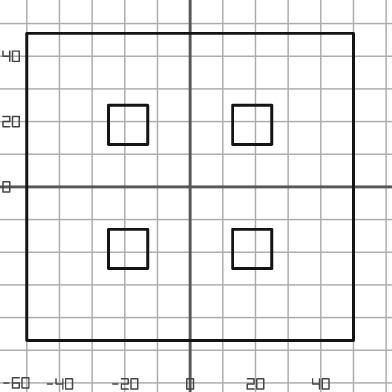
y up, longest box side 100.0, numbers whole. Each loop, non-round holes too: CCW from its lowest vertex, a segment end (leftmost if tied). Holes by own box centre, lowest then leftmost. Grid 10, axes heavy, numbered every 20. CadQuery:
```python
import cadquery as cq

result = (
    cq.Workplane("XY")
    .moveTo(-50.0, -47.0)
    .lineTo(50.0, -47.0)
    .lineTo(50.0, 47.0)
    .lineTo(-50.0, 47.0)
    .close()
    .moveTo(-25.0, -25.0)
    .lineTo(-13.0, -25.0)
    .lineTo(-13.0, -13.0)
    .lineTo(-25.0, -13.0)
    .close()
    .moveTo(13.0, -25.0)
    .lineTo(25.0, -25.0)
    .lineTo(25.0, -13.0)
    .lineTo(13.0, -13.0)
    .close()
    .moveTo(-25.0, 13.0)
    .lineTo(-13.0, 13.0)
    .lineTo(-13.0, 25.0)
    .lineTo(-25.0, 25.0)
    .close()
    .moveTo(13.0, 13.0)
    .lineTo(25.0, 13.0)
    .lineTo(25.0, 25.0)
    .lineTo(13.0, 25.0)
    .close()
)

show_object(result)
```